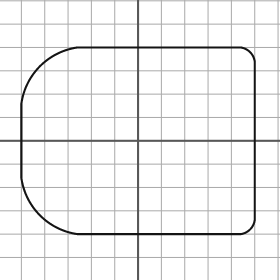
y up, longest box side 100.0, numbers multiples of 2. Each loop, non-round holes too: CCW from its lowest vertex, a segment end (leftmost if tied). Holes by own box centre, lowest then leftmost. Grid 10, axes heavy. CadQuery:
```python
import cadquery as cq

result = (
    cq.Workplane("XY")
    .moveTo(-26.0, -40.0)
    .lineTo(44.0, -40.0)
    .threePointArc((48.0, -38.0), (50.0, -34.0))
    .lineTo(50.0, 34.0)
    .threePointArc((48.0, 38.0), (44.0, 40.0))
    .lineTo(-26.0, 40.0)
    .threePointArc((-42.0, 32.0), (-50.0, 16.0))
    .lineTo(-50.0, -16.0)
    .threePointArc((-42.0, -32.0), (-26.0, -40.0))
    .close()
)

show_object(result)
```